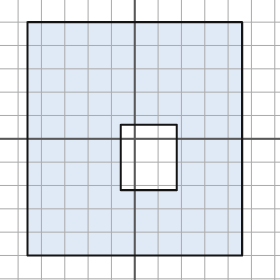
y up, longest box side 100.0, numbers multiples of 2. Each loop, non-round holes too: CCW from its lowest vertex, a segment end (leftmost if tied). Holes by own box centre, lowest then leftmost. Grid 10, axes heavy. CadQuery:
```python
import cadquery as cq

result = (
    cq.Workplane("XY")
    .moveTo(-46.0, -50.0)
    .lineTo(46.0, -50.0)
    .lineTo(46.0, 50.0)
    .lineTo(-46.0, 50.0)
    .close()
    .moveTo(-6.0, -22.0)
    .lineTo(18.0, -22.0)
    .lineTo(18.0, 6.0)
    .lineTo(-6.0, 6.0)
    .close()
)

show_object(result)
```